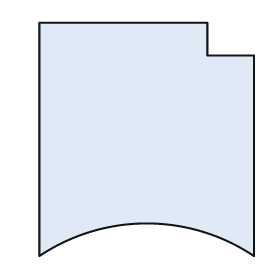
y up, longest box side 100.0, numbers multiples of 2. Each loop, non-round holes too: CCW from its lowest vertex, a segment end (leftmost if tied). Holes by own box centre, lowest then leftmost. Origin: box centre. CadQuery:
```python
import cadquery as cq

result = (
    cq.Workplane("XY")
    .moveTo(-46.0, -50.0)
    .threePointArc((0.0, -36.0), (46.0, -50.0))
    .lineTo(46.0, 36.0)
    .lineTo(26.0, 36.0)
    .lineTo(26.0, 50.0)
    .lineTo(-46.0, 50.0)
    .close()
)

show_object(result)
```